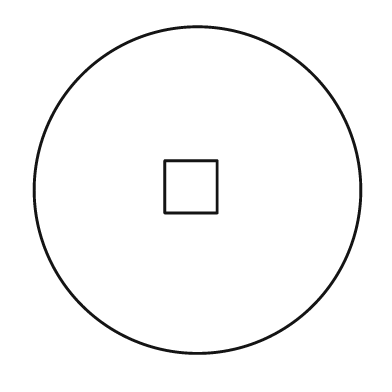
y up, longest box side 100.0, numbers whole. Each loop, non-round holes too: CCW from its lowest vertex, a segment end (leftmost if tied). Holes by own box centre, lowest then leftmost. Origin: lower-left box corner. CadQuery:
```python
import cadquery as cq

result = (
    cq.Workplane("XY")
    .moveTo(50.0, 50.0)
    .circle(50.0)
    .moveTo(40.0, 43.0)
    .lineTo(56.0, 43.0)
    .lineTo(56.0, 59.0)
    .lineTo(40.0, 59.0)
    .close()
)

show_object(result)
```